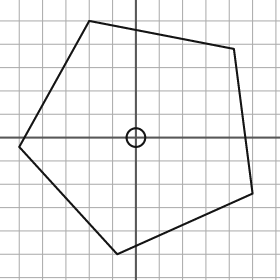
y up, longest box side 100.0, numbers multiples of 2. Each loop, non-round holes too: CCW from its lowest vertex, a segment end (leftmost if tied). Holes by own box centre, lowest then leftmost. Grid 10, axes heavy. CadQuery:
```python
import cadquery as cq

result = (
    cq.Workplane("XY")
    .moveTo(-8.0, -50.0)
    .lineTo(50.0, -24.0)
    .lineTo(42.0, 38.0)
    .lineTo(-20.0, 50.0)
    .lineTo(-50.0, -4.0)
    .close()
    .moveTo(0.0, 0.0)
    .circle(4.0)
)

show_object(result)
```